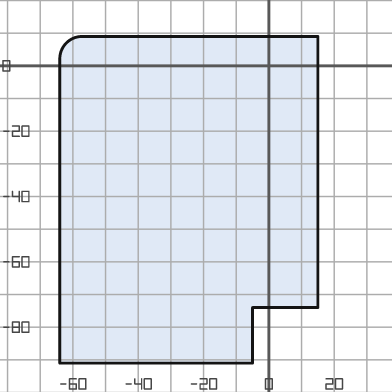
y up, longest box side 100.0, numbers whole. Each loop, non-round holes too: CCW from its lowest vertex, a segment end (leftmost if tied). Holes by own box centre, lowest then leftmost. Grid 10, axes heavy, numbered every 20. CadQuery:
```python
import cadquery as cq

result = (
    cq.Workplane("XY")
    .moveTo(-64.0, -91.0)
    .lineTo(-5.0, -91.0)
    .lineTo(-5.0, -74.0)
    .lineTo(15.0, -74.0)
    .lineTo(15.0, 9.0)
    .lineTo(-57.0, 9.0)
    .threePointArc((-62.0, 7.0), (-64.0, 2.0))
    .close()
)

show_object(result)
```